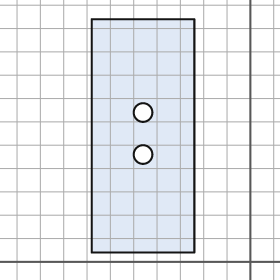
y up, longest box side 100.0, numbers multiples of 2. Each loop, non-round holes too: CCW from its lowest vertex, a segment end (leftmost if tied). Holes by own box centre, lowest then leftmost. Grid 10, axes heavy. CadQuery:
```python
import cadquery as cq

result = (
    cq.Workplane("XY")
    .moveTo(-68.0, 4.0)
    .lineTo(-24.0, 4.0)
    .lineTo(-24.0, 104.0)
    .lineTo(-68.0, 104.0)
    .close()
    .moveTo(-46.0, 46.0)
    .circle(4.0)
    .moveTo(-46.0, 64.0)
    .circle(4.0)
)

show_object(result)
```